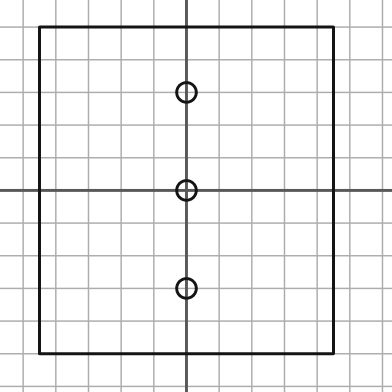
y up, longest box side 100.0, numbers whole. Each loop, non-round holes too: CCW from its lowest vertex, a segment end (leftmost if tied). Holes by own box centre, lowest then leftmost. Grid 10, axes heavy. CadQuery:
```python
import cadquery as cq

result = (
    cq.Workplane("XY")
    .moveTo(-45.0, -50.0)
    .lineTo(45.0, -50.0)
    .lineTo(45.0, 50.0)
    .lineTo(-45.0, 50.0)
    .close()
    .moveTo(0.0, -30.0)
    .circle(3.0)
    .moveTo(0.0, 0.0)
    .circle(3.0)
    .moveTo(0.0, 30.0)
    .circle(3.0)
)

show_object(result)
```